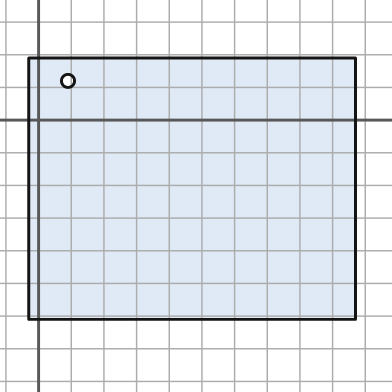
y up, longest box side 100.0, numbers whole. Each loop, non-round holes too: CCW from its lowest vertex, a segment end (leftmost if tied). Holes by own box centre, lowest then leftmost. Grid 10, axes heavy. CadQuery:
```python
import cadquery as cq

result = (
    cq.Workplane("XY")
    .moveTo(-3.0, -61.0)
    .lineTo(97.0, -61.0)
    .lineTo(97.0, 19.0)
    .lineTo(-3.0, 19.0)
    .close()
    .moveTo(9.0, 12.0)
    .circle(2.0)
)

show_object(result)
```